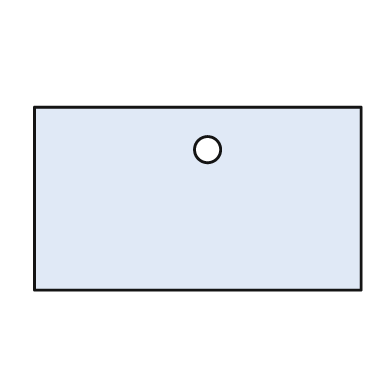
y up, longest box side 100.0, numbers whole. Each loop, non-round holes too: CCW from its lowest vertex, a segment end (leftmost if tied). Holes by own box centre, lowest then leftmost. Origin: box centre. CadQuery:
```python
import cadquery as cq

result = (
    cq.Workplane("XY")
    .moveTo(-50.0, -28.0)
    .lineTo(50.0, -28.0)
    .lineTo(50.0, 28.0)
    .lineTo(-50.0, 28.0)
    .close()
    .moveTo(3.0, 15.0)
    .circle(4.0)
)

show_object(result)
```